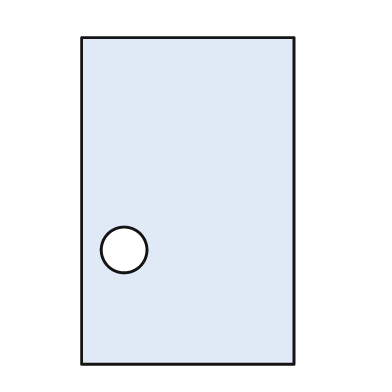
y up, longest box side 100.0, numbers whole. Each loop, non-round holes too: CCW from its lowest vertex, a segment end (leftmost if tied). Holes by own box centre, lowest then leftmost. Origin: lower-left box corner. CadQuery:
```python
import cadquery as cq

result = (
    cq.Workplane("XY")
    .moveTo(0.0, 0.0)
    .lineTo(65.0, 0.0)
    .lineTo(65.0, 100.0)
    .lineTo(0.0, 100.0)
    .close()
    .moveTo(13.0, 35.0)
    .circle(7.0)
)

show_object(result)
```